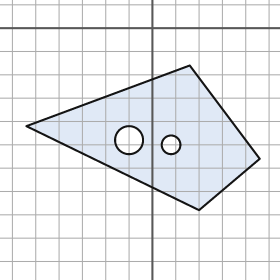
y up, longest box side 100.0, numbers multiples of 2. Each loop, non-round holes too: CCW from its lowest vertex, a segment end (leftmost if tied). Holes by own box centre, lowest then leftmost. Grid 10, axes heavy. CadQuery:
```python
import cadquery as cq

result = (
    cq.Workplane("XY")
    .moveTo(20.0, -78.0)
    .lineTo(46.0, -56.0)
    .lineTo(16.0, -16.0)
    .lineTo(-54.0, -42.0)
    .close()
    .moveTo(8.0, -50.0)
    .circle(4.0)
    .moveTo(-10.0, -48.0)
    .circle(6.0)
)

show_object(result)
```